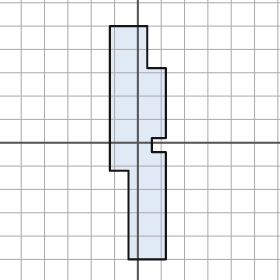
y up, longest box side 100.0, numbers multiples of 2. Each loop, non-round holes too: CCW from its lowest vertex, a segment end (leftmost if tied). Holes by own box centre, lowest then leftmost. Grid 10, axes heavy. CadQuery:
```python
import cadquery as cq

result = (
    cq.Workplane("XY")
    .moveTo(-4.0, -50.0)
    .lineTo(12.0, -50.0)
    .lineTo(12.0, -4.0)
    .lineTo(6.0, -4.0)
    .lineTo(6.0, 2.0)
    .lineTo(12.0, 2.0)
    .lineTo(12.0, 32.0)
    .lineTo(4.0, 32.0)
    .lineTo(4.0, 50.0)
    .lineTo(-12.0, 50.0)
    .lineTo(-12.0, -12.0)
    .lineTo(-4.0, -12.0)
    .close()
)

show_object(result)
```